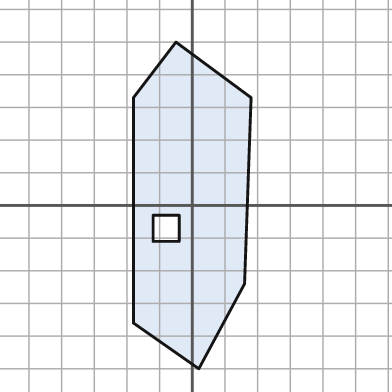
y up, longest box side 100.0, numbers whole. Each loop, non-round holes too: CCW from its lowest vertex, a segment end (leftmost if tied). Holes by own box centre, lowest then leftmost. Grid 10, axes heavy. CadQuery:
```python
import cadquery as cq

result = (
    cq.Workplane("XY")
    .moveTo(2.0, -50.0)
    .lineTo(16.0, -24.0)
    .lineTo(18.0, 33.0)
    .lineTo(-5.0, 50.0)
    .lineTo(-18.0, 33.0)
    .lineTo(-18.0, -36.0)
    .close()
    .moveTo(-12.0, -11.0)
    .lineTo(-4.0, -11.0)
    .lineTo(-4.0, -3.0)
    .lineTo(-12.0, -3.0)
    .close()
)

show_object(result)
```